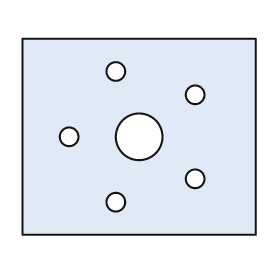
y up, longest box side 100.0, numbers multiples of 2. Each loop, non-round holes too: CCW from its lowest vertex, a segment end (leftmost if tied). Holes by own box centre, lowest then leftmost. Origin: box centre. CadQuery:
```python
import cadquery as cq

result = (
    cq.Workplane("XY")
    .moveTo(-50.0, -42.0)
    .lineTo(50.0, -42.0)
    .lineTo(50.0, 42.0)
    .lineTo(-50.0, 42.0)
    .close()
    .moveTo(-10.0, -28.0)
    .circle(4.0)
    .moveTo(24.0, -18.0)
    .circle(4.0)
    .moveTo(-30.0, 0.0)
    .circle(4.0)
    .moveTo(0.0, 0.0)
    .circle(10.0)
    .moveTo(24.0, 18.0)
    .circle(4.0)
    .moveTo(-10.0, 28.0)
    .circle(4.0)
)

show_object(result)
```